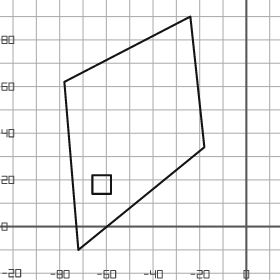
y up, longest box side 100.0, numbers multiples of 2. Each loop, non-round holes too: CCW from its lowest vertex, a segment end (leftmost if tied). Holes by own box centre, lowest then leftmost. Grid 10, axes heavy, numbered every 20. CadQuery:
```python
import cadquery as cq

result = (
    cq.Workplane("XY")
    .moveTo(-72.0, -10.0)
    .lineTo(-18.0, 34.0)
    .lineTo(-24.0, 90.0)
    .lineTo(-78.0, 62.0)
    .close()
    .moveTo(-66.0, 14.0)
    .lineTo(-58.0, 14.0)
    .lineTo(-58.0, 22.0)
    .lineTo(-66.0, 22.0)
    .close()
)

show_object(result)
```